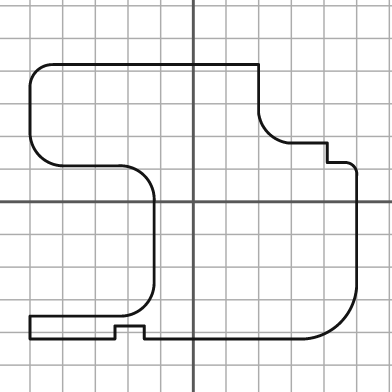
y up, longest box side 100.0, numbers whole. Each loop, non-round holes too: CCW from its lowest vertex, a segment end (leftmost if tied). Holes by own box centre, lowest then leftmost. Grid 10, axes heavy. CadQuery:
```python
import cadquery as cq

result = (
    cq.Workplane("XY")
    .moveTo(-50.0, -42.0)
    .lineTo(-24.0, -42.0)
    .lineTo(-24.0, -38.0)
    .lineTo(-15.0, -38.0)
    .lineTo(-15.0, -42.0)
    .lineTo(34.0, -42.0)
    .threePointArc((45.0, -37.0), (50.0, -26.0))
    .lineTo(50.0, 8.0)
    .threePointArc((49.0, 11.0), (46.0, 12.0))
    .lineTo(41.0, 12.0)
    .lineTo(41.0, 18.0)
    .lineTo(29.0, 18.0)
    .threePointArc((23.0, 21.0), (20.0, 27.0))
    .lineTo(20.0, 42.0)
    .lineTo(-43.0, 42.0)
    .threePointArc((-48.0, 40.0), (-50.0, 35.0))
    .lineTo(-50.0, 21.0)
    .threePointArc((-47.0, 14.0), (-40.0, 11.0))
    .lineTo(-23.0, 11.0)
    .threePointArc((-15.0, 8.0), (-12.0, 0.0))
    .lineTo(-12.0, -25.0)
    .threePointArc((-15.0, -32.0), (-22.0, -35.0))
    .lineTo(-50.0, -35.0)
    .close()
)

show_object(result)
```